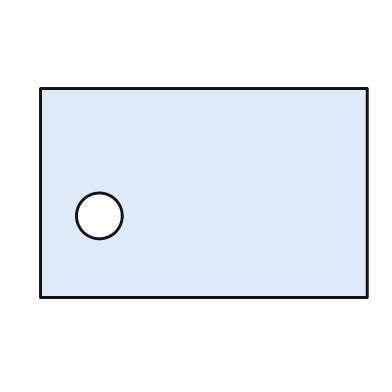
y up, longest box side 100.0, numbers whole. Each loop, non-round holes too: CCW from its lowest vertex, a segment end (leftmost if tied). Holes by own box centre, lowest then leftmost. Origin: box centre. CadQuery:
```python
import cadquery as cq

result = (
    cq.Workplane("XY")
    .moveTo(-50.0, -32.0)
    .lineTo(50.0, -32.0)
    .lineTo(50.0, 32.0)
    .lineTo(-50.0, 32.0)
    .close()
    .moveTo(-32.0, -7.0)
    .circle(7.0)
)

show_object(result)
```